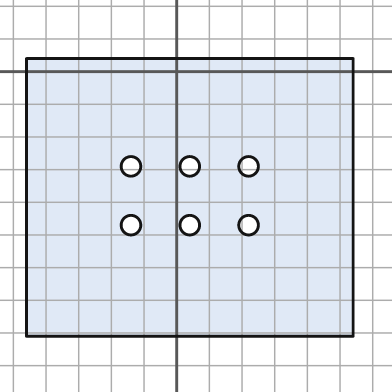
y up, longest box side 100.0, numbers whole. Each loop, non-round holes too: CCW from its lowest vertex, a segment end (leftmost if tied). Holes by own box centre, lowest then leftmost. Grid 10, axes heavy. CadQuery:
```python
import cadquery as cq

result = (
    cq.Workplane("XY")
    .moveTo(-46.0, -81.0)
    .lineTo(54.0, -81.0)
    .lineTo(54.0, 4.0)
    .lineTo(-46.0, 4.0)
    .close()
    .moveTo(-14.0, -47.0)
    .circle(3.0)
    .moveTo(4.0, -47.0)
    .circle(3.0)
    .moveTo(22.0, -47.0)
    .circle(3.0)
    .moveTo(-14.0, -29.0)
    .circle(3.0)
    .moveTo(4.0, -29.0)
    .circle(3.0)
    .moveTo(22.0, -29.0)
    .circle(3.0)
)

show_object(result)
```